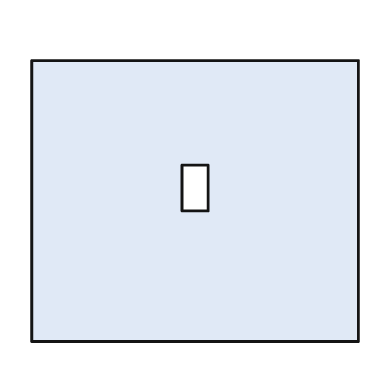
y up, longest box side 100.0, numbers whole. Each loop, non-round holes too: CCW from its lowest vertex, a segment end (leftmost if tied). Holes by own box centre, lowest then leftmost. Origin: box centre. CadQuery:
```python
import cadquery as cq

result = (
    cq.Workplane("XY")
    .moveTo(-50.0, -43.0)
    .lineTo(50.0, -43.0)
    .lineTo(50.0, 43.0)
    .lineTo(-50.0, 43.0)
    .close()
    .moveTo(-4.0, -3.0)
    .lineTo(4.0, -3.0)
    .lineTo(4.0, 11.0)
    .lineTo(-4.0, 11.0)
    .close()
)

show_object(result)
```